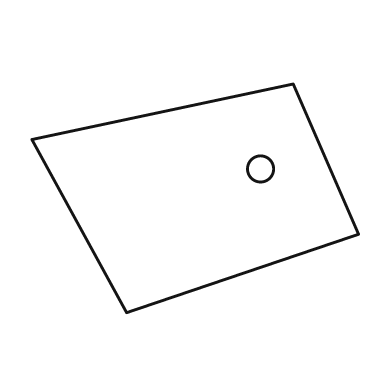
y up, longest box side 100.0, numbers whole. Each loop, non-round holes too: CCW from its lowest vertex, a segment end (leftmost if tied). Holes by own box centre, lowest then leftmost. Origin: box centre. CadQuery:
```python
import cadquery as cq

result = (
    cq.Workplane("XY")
    .moveTo(-21.0, -35.0)
    .lineTo(50.0, -11.0)
    .lineTo(30.0, 35.0)
    .lineTo(-50.0, 18.0)
    .close()
    .moveTo(20.0, 9.0)
    .circle(4.0)
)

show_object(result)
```